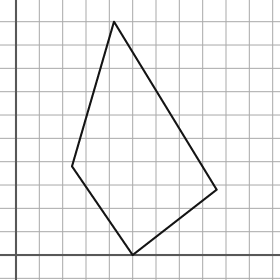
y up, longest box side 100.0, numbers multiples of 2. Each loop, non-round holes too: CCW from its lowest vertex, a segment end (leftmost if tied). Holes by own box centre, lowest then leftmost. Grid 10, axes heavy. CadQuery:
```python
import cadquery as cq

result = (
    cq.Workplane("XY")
    .moveTo(50.0, 0.0)
    .lineTo(86.0, 28.0)
    .lineTo(42.0, 100.0)
    .lineTo(24.0, 38.0)
    .close()
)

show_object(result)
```